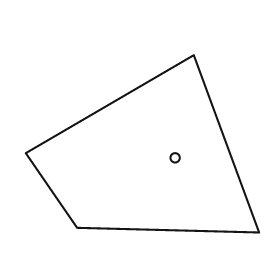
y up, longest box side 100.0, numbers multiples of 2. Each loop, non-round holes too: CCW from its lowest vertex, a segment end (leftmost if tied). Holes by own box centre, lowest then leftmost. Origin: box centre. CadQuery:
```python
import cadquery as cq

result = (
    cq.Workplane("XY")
    .moveTo(50.0, -38.0)
    .lineTo(22.0, 38.0)
    .lineTo(-50.0, -4.0)
    .lineTo(-28.0, -36.0)
    .close()
    .moveTo(14.0, -6.0)
    .circle(2.0)
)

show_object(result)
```